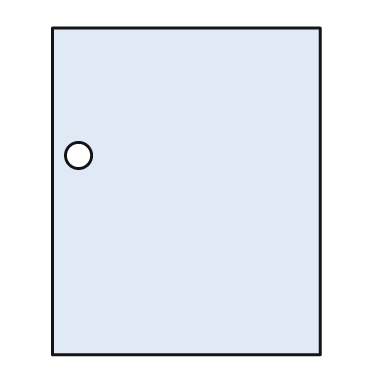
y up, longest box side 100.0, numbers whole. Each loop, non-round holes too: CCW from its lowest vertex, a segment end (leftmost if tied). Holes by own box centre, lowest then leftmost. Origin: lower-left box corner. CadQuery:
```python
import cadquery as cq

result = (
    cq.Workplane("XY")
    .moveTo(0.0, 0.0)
    .lineTo(82.0, 0.0)
    .lineTo(82.0, 100.0)
    .lineTo(0.0, 100.0)
    .close()
    .moveTo(8.0, 61.0)
    .circle(4.0)
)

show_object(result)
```